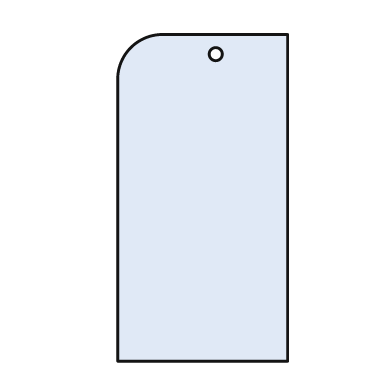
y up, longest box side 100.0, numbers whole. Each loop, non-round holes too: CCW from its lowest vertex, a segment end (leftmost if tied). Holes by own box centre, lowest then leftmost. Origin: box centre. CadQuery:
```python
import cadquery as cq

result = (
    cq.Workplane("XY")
    .moveTo(-26.0, -50.0)
    .lineTo(26.0, -50.0)
    .lineTo(26.0, 50.0)
    .lineTo(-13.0, 50.0)
    .threePointArc((-22.0, 46.0), (-26.0, 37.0))
    .close()
    .moveTo(4.0, 44.0)
    .circle(2.0)
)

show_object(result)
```